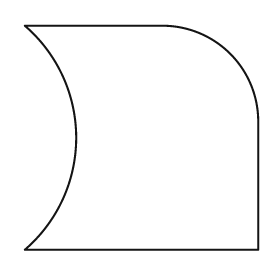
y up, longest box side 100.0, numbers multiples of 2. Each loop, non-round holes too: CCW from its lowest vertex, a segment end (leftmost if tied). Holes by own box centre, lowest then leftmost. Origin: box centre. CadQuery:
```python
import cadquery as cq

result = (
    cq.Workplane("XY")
    .moveTo(-50.0, -48.0)
    .lineTo(50.0, -48.0)
    .lineTo(50.0, 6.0)
    .threePointArc((38.0, 36.0), (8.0, 48.0))
    .lineTo(-50.0, 48.0)
    .threePointArc((-28.0, 0.0), (-50.0, -48.0))
    .close()
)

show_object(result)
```